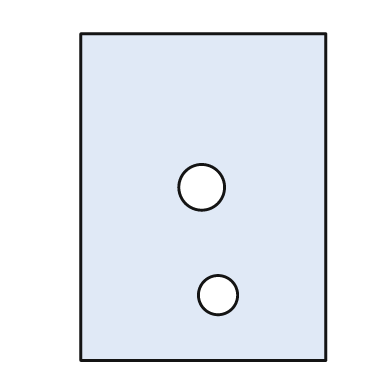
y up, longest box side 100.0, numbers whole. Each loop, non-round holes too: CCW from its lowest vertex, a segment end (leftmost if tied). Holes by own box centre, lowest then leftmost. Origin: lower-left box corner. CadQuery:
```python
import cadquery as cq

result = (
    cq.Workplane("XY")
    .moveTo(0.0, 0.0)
    .lineTo(75.0, 0.0)
    .lineTo(75.0, 100.0)
    .lineTo(0.0, 100.0)
    .close()
    .moveTo(42.0, 20.0)
    .circle(6.0)
    .moveTo(37.0, 53.0)
    .circle(7.0)
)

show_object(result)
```